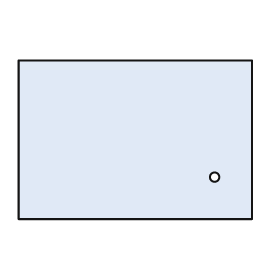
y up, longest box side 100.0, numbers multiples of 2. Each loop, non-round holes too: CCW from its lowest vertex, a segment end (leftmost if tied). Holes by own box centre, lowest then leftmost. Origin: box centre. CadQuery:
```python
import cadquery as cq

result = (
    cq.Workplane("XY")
    .moveTo(-50.0, -34.0)
    .lineTo(50.0, -34.0)
    .lineTo(50.0, 34.0)
    .lineTo(-50.0, 34.0)
    .close()
    .moveTo(34.0, -16.0)
    .circle(2.0)
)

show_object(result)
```